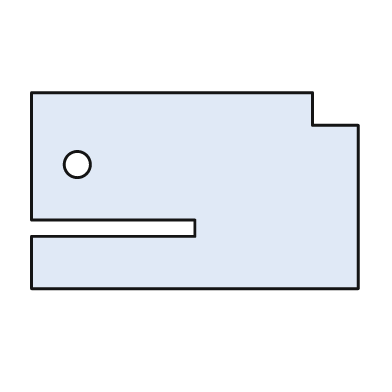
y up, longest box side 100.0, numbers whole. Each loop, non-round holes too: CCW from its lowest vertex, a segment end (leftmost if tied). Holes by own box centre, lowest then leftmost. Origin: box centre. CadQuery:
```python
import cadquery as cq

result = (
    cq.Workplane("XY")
    .moveTo(-50.0, -30.0)
    .lineTo(50.0, -30.0)
    .lineTo(50.0, 20.0)
    .lineTo(36.0, 20.0)
    .lineTo(36.0, 30.0)
    .lineTo(-50.0, 30.0)
    .lineTo(-50.0, -9.0)
    .lineTo(0.0, -9.0)
    .lineTo(0.0, -14.0)
    .lineTo(-50.0, -14.0)
    .close()
    .moveTo(-36.0, 8.0)
    .circle(4.0)
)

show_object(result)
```